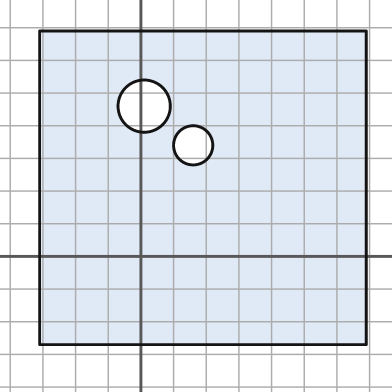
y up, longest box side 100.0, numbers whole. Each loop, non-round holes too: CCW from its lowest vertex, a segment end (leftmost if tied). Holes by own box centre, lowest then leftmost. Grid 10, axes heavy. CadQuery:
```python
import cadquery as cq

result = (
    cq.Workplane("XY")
    .moveTo(-31.0, -27.0)
    .lineTo(69.0, -27.0)
    .lineTo(69.0, 69.0)
    .lineTo(-31.0, 69.0)
    .close()
    .moveTo(16.0, 34.0)
    .circle(6.0)
    .moveTo(1.0, 46.0)
    .circle(8.0)
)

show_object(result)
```